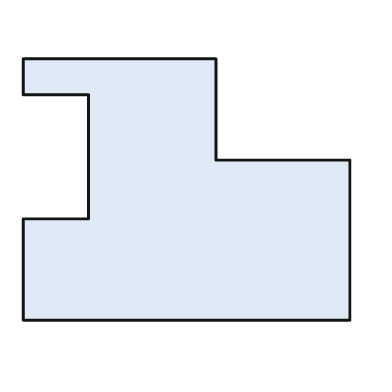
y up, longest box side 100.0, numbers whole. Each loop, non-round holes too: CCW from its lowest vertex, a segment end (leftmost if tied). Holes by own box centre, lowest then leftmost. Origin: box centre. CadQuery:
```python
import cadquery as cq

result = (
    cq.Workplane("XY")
    .moveTo(-50.0, -40.0)
    .lineTo(50.0, -40.0)
    .lineTo(50.0, 9.0)
    .lineTo(9.0, 9.0)
    .lineTo(9.0, 40.0)
    .lineTo(-50.0, 40.0)
    .lineTo(-50.0, 29.0)
    .lineTo(-30.0, 29.0)
    .lineTo(-30.0, -9.0)
    .lineTo(-50.0, -9.0)
    .close()
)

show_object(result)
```